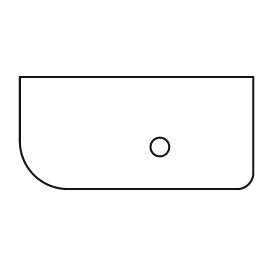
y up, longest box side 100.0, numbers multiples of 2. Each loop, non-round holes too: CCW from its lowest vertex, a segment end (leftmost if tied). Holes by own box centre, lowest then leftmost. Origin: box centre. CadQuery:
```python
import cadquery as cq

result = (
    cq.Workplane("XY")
    .moveTo(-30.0, -24.0)
    .lineTo(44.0, -24.0)
    .threePointArc((48.0, -22.0), (50.0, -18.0))
    .lineTo(50.0, 24.0)
    .lineTo(-50.0, 24.0)
    .lineTo(-50.0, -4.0)
    .threePointArc((-44.0, -18.0), (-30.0, -24.0))
    .close()
    .moveTo(10.0, -6.0)
    .circle(4.0)
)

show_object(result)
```